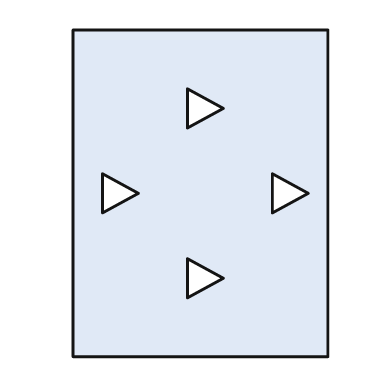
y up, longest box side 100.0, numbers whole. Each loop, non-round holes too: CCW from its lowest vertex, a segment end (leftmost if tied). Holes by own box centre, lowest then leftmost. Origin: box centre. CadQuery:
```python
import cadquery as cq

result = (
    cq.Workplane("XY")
    .moveTo(-39.0, -50.0)
    .lineTo(39.0, -50.0)
    .lineTo(39.0, 50.0)
    .lineTo(-39.0, 50.0)
    .close()
    .moveTo(-4.0, -32.0)
    .lineTo(7.0, -26.0)
    .lineTo(-4.0, -20.0)
    .close()
    .moveTo(-30.0, -6.0)
    .lineTo(-19.0, 0.0)
    .lineTo(-30.0, 6.0)
    .close()
    .moveTo(22.0, -6.0)
    .lineTo(33.0, 0.0)
    .lineTo(22.0, 6.0)
    .close()
    .moveTo(-4.0, 20.0)
    .lineTo(7.0, 26.0)
    .lineTo(-4.0, 32.0)
    .close()
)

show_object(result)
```